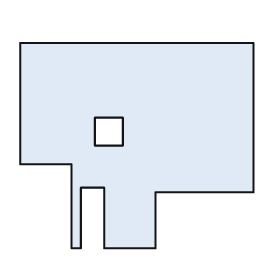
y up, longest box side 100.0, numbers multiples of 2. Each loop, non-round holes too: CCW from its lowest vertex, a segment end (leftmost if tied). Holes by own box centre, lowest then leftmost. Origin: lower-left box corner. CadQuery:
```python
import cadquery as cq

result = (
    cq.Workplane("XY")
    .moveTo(22.0, 0.0)
    .lineTo(26.0, 0.0)
    .lineTo(26.0, 26.0)
    .lineTo(36.0, 26.0)
    .lineTo(36.0, 0.0)
    .lineTo(58.0, 0.0)
    .lineTo(58.0, 24.0)
    .lineTo(100.0, 24.0)
    .lineTo(100.0, 88.0)
    .lineTo(0.0, 88.0)
    .lineTo(0.0, 36.0)
    .lineTo(22.0, 36.0)
    .close()
    .moveTo(32.0, 44.0)
    .lineTo(44.0, 44.0)
    .lineTo(44.0, 56.0)
    .lineTo(32.0, 56.0)
    .close()
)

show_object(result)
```